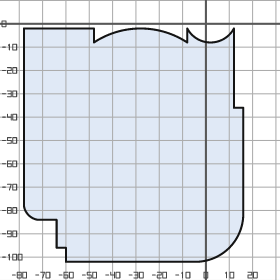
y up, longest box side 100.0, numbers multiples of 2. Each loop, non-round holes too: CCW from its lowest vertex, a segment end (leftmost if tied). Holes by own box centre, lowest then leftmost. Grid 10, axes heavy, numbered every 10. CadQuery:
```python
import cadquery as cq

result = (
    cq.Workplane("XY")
    .moveTo(-60.0, -102.0)
    .lineTo(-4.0, -102.0)
    .threePointArc((10.0, -96.0), (16.0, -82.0))
    .lineTo(16.0, -36.0)
    .lineTo(12.0, -36.0)
    .lineTo(12.0, -2.0)
    .threePointArc((2.0, -8.0), (-8.0, -2.0))
    .lineTo(-8.0, -8.0)
    .threePointArc((-28.0, -2.0), (-48.0, -8.0))
    .lineTo(-48.0, -2.0)
    .lineTo(-78.0, -2.0)
    .lineTo(-78.0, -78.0)
    .threePointArc((-76.0, -82.0), (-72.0, -84.0))
    .lineTo(-64.0, -84.0)
    .lineTo(-64.0, -96.0)
    .lineTo(-60.0, -96.0)
    .close()
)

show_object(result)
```